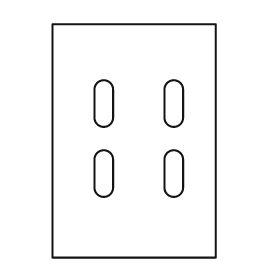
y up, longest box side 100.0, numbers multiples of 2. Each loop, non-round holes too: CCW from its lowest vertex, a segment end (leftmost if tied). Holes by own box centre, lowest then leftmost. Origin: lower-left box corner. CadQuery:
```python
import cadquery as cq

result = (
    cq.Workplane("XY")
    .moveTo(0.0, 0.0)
    .lineTo(70.0, 0.0)
    .lineTo(70.0, 100.0)
    .lineTo(0.0, 100.0)
    .close()
    .moveTo(18.0, 30.0)
    .threePointArc((22.0, 26.0), (26.0, 30.0))
    .lineTo(26.0, 42.0)
    .threePointArc((22.0, 46.0), (18.0, 42.0))
    .close()
    .moveTo(48.0, 30.0)
    .threePointArc((52.0, 26.0), (56.0, 30.0))
    .lineTo(56.0, 42.0)
    .threePointArc((52.0, 46.0), (48.0, 42.0))
    .close()
    .moveTo(18.0, 60.0)
    .threePointArc((22.0, 56.0), (26.0, 60.0))
    .lineTo(26.0, 72.0)
    .threePointArc((22.0, 76.0), (18.0, 72.0))
    .close()
    .moveTo(48.0, 60.0)
    .threePointArc((52.0, 56.0), (56.0, 60.0))
    .lineTo(56.0, 72.0)
    .threePointArc((52.0, 76.0), (48.0, 72.0))
    .close()
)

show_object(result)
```